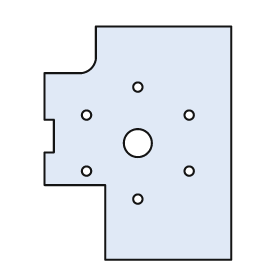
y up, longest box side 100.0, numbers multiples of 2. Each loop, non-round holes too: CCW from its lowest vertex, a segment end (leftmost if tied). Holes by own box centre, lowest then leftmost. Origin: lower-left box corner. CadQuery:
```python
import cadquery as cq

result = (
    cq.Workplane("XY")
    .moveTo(26.0, 0.0)
    .lineTo(80.0, 0.0)
    .lineTo(80.0, 100.0)
    .lineTo(22.0, 100.0)
    .lineTo(22.0, 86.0)
    .threePointArc((20.0, 82.0), (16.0, 80.0))
    .lineTo(0.0, 80.0)
    .lineTo(0.0, 60.0)
    .lineTo(4.0, 60.0)
    .lineTo(4.0, 46.0)
    .lineTo(0.0, 46.0)
    .lineTo(0.0, 32.0)
    .lineTo(26.0, 32.0)
    .close()
    .moveTo(40.0, 26.0)
    .circle(2.0)
    .moveTo(18.0, 38.0)
    .circle(2.0)
    .moveTo(62.0, 38.0)
    .circle(2.0)
    .moveTo(40.0, 50.0)
    .circle(6.0)
    .moveTo(18.0, 62.0)
    .circle(2.0)
    .moveTo(62.0, 62.0)
    .circle(2.0)
    .moveTo(40.0, 74.0)
    .circle(2.0)
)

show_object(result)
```